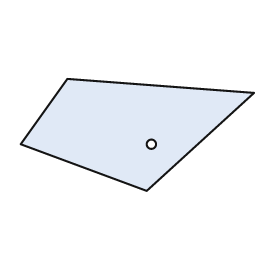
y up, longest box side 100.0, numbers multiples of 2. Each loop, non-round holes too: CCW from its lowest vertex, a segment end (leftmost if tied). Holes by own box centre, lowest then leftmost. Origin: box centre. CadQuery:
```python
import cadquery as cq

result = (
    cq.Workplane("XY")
    .moveTo(4.0, -24.0)
    .lineTo(50.0, 18.0)
    .lineTo(-30.0, 24.0)
    .lineTo(-50.0, -4.0)
    .close()
    .moveTo(6.0, -4.0)
    .circle(2.0)
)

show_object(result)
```